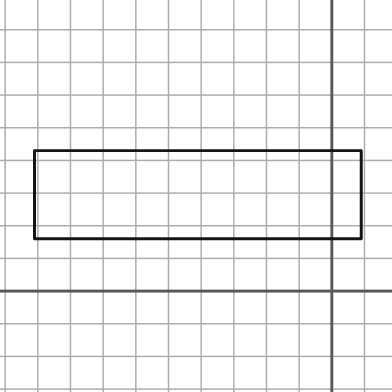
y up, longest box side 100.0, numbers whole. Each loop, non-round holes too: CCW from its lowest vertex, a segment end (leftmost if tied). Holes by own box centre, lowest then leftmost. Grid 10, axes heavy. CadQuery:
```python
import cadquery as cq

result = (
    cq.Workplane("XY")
    .moveTo(-91.0, 16.0)
    .lineTo(9.0, 16.0)
    .lineTo(9.0, 43.0)
    .lineTo(-91.0, 43.0)
    .close()
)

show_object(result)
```